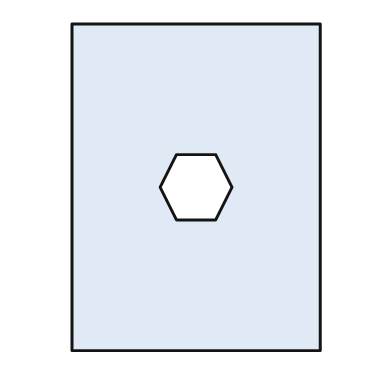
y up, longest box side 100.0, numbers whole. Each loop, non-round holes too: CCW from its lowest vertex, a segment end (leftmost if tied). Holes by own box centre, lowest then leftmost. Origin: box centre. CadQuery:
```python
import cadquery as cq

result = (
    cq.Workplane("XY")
    .moveTo(-38.0, -50.0)
    .lineTo(38.0, -50.0)
    .lineTo(38.0, 50.0)
    .lineTo(-38.0, 50.0)
    .close()
    .moveTo(-6.0, -10.0)
    .lineTo(6.0, -10.0)
    .lineTo(11.0, 0.0)
    .lineTo(6.0, 10.0)
    .lineTo(-6.0, 10.0)
    .lineTo(-11.0, 0.0)
    .close()
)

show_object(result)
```